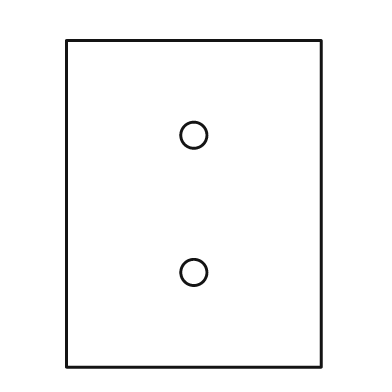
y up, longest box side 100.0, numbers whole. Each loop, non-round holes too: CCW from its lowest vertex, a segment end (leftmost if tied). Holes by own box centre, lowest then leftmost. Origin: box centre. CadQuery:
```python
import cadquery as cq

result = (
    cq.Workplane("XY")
    .moveTo(-39.0, -50.0)
    .lineTo(39.0, -50.0)
    .lineTo(39.0, 50.0)
    .lineTo(-39.0, 50.0)
    .close()
    .moveTo(0.0, -21.0)
    .circle(4.0)
    .moveTo(0.0, 21.0)
    .circle(4.0)
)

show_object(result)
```